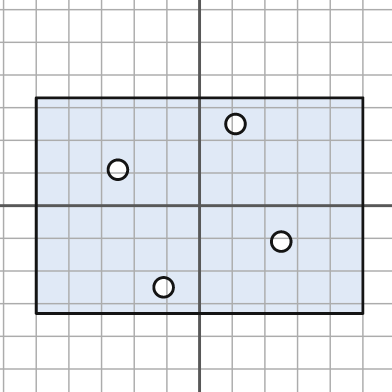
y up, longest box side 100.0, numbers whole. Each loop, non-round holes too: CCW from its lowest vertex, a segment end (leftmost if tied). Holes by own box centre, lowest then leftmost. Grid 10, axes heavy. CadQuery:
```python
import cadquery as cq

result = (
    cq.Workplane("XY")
    .moveTo(-50.0, -33.0)
    .lineTo(50.0, -33.0)
    .lineTo(50.0, 33.0)
    .lineTo(-50.0, 33.0)
    .close()
    .moveTo(-11.0, -25.0)
    .circle(3.0)
    .moveTo(25.0, -11.0)
    .circle(3.0)
    .moveTo(-25.0, 11.0)
    .circle(3.0)
    .moveTo(11.0, 25.0)
    .circle(3.0)
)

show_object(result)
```